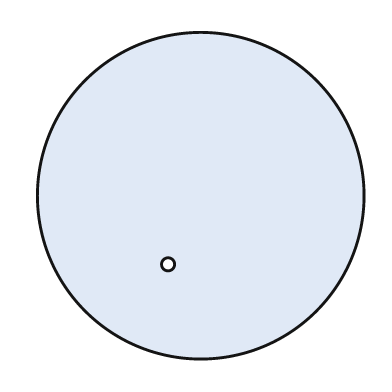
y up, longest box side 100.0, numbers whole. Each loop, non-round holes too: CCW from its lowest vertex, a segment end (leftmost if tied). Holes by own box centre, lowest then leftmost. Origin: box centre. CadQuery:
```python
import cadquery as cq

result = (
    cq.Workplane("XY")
    .moveTo(0.0, 0.0)
    .circle(50.0)
    .moveTo(-10.0, -21.0)
    .circle(2.0)
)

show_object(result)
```